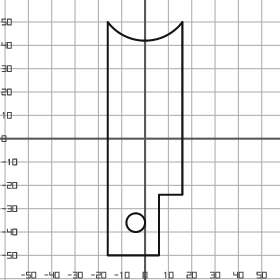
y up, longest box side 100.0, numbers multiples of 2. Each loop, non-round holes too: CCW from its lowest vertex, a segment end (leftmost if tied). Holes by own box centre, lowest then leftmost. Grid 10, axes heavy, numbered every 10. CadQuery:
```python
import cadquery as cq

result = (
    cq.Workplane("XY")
    .moveTo(-16.0, -50.0)
    .lineTo(6.0, -50.0)
    .lineTo(6.0, -24.0)
    .lineTo(16.0, -24.0)
    .lineTo(16.0, 50.0)
    .threePointArc((0.0, 42.0), (-16.0, 50.0))
    .close()
    .moveTo(-4.0, -36.0)
    .circle(4.0)
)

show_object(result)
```